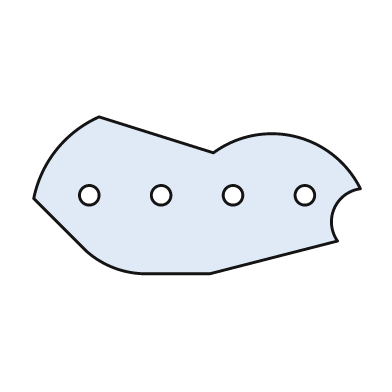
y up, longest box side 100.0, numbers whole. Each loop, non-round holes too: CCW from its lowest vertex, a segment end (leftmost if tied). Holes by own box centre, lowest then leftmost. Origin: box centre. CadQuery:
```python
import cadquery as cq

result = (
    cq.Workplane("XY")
    .moveTo(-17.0, -24.0)
    .lineTo(4.0, -24.0)
    .lineTo(43.0, -14.0)
    .threePointArc((42.0, -4.0), (50.0, 2.0))
    .threePointArc((30.0, 18.0), (5.0, 13.0))
    .lineTo(-30.0, 24.0)
    .threePointArc((-43.0, 14.0), (-50.0, -1.0))
    .lineTo(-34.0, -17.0)
    .threePointArc((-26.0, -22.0), (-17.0, -24.0))
    .close()
    .moveTo(-33.0, 0.0)
    .circle(3.0)
    .moveTo(-11.0, 0.0)
    .circle(3.0)
    .moveTo(11.0, 0.0)
    .circle(3.0)
    .moveTo(33.0, 0.0)
    .circle(3.0)
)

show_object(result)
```